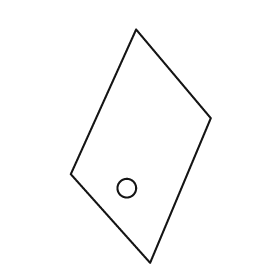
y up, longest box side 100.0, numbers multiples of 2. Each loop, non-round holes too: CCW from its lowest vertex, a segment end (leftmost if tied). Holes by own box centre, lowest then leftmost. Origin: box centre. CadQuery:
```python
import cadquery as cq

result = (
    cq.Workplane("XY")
    .moveTo(4.0, -50.0)
    .lineTo(30.0, 12.0)
    .lineTo(-2.0, 50.0)
    .lineTo(-30.0, -12.0)
    .close()
    .moveTo(-6.0, -18.0)
    .circle(4.0)
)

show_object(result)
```